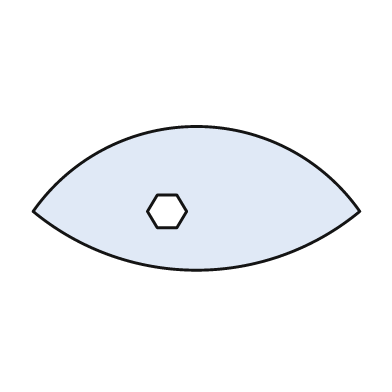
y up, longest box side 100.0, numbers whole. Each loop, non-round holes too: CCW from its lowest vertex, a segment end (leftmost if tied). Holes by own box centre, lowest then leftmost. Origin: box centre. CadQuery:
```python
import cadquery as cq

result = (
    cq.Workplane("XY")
    .moveTo(-50.0, -4.0)
    .threePointArc((0.0, -22.0), (50.0, -4.0))
    .threePointArc((0.0, 22.0), (-50.0, -4.0))
    .close()
    .moveTo(-12.0, -9.0)
    .lineTo(-6.0, -9.0)
    .lineTo(-3.0, -4.0)
    .lineTo(-6.0, 1.0)
    .lineTo(-12.0, 1.0)
    .lineTo(-15.0, -4.0)
    .close()
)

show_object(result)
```